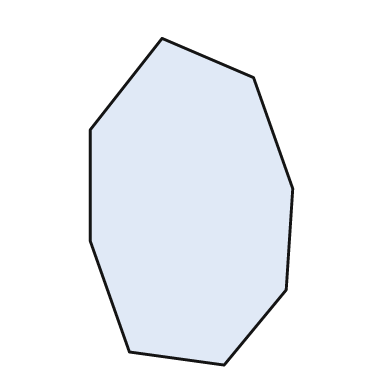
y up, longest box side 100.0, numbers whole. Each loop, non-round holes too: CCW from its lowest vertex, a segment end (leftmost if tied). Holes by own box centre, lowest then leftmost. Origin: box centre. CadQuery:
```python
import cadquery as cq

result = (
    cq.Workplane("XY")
    .moveTo(10.0, -50.0)
    .lineTo(29.0, -27.0)
    .lineTo(31.0, 4.0)
    .lineTo(19.0, 38.0)
    .lineTo(-9.0, 50.0)
    .lineTo(-31.0, 22.0)
    .lineTo(-31.0, -12.0)
    .lineTo(-19.0, -46.0)
    .close()
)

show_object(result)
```